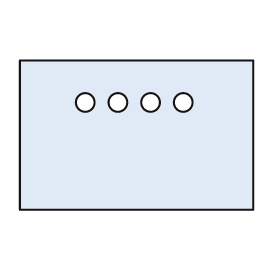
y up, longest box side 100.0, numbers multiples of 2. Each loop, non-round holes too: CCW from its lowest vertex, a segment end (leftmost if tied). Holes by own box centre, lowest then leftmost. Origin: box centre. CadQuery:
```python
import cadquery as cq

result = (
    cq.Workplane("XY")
    .moveTo(-50.0, -32.0)
    .lineTo(50.0, -32.0)
    .lineTo(50.0, 32.0)
    .lineTo(-50.0, 32.0)
    .close()
    .moveTo(-22.0, 14.0)
    .circle(4.0)
    .moveTo(-8.0, 14.0)
    .circle(4.0)
    .moveTo(6.0, 14.0)
    .circle(4.0)
    .moveTo(20.0, 14.0)
    .circle(4.0)
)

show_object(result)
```